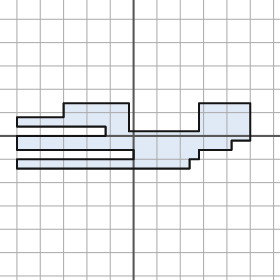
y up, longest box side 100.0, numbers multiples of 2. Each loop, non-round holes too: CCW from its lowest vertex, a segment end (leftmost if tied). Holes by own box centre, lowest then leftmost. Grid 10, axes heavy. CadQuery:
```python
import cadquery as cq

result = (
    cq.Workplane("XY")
    .moveTo(-50.0, -14.0)
    .lineTo(24.0, -14.0)
    .lineTo(24.0, -10.0)
    .lineTo(28.0, -10.0)
    .lineTo(28.0, -6.0)
    .lineTo(42.0, -6.0)
    .lineTo(42.0, -2.0)
    .lineTo(50.0, -2.0)
    .lineTo(50.0, 14.0)
    .lineTo(28.0, 14.0)
    .lineTo(28.0, 2.0)
    .lineTo(-2.0, 2.0)
    .lineTo(-2.0, 14.0)
    .lineTo(-30.0, 14.0)
    .lineTo(-30.0, 8.0)
    .lineTo(-50.0, 8.0)
    .lineTo(-50.0, 4.0)
    .lineTo(-12.0, 4.0)
    .lineTo(-12.0, 0.0)
    .lineTo(-50.0, 0.0)
    .lineTo(-50.0, -6.0)
    .lineTo(0.0, -6.0)
    .lineTo(0.0, -10.0)
    .lineTo(-50.0, -10.0)
    .close()
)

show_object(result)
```